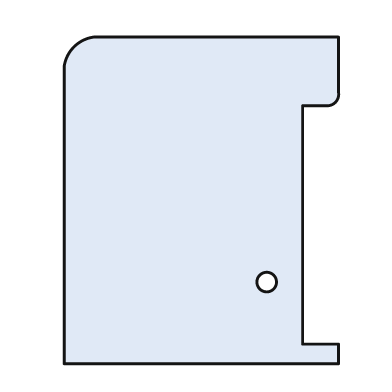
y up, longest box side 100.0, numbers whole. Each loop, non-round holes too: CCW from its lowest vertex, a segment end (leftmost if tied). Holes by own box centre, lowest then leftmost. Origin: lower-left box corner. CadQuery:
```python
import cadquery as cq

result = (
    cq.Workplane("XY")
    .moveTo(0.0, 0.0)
    .lineTo(84.0, 0.0)
    .lineTo(84.0, 6.0)
    .lineTo(73.0, 6.0)
    .lineTo(73.0, 79.0)
    .lineTo(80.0, 79.0)
    .threePointArc((83.0, 80.0), (84.0, 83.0))
    .lineTo(84.0, 100.0)
    .lineTo(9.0, 100.0)
    .threePointArc((3.0, 97.0), (0.0, 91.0))
    .close()
    .moveTo(62.0, 25.0)
    .circle(3.0)
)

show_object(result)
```